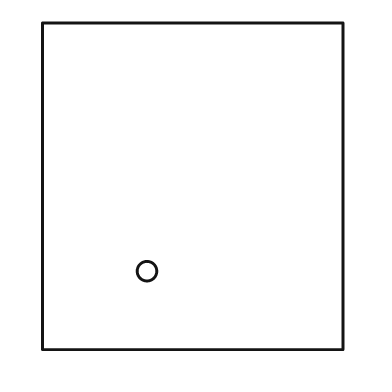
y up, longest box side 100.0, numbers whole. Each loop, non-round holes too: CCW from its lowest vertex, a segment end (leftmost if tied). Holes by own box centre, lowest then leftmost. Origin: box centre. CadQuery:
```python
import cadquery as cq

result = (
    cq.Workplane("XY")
    .moveTo(-46.0, -50.0)
    .lineTo(46.0, -50.0)
    .lineTo(46.0, 50.0)
    .lineTo(-46.0, 50.0)
    .close()
    .moveTo(-14.0, -26.0)
    .circle(3.0)
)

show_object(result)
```